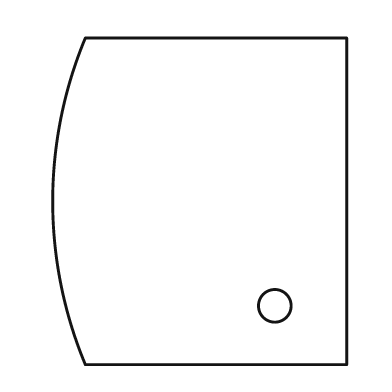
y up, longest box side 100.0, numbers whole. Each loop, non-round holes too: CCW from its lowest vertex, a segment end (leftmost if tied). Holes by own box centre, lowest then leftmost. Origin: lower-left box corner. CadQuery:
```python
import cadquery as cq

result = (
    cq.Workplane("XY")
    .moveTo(10.0, 0.0)
    .lineTo(90.0, 0.0)
    .lineTo(90.0, 100.0)
    .lineTo(10.0, 100.0)
    .threePointArc((0.0, 50.0), (10.0, 0.0))
    .close()
    .moveTo(68.0, 18.0)
    .circle(5.0)
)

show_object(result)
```